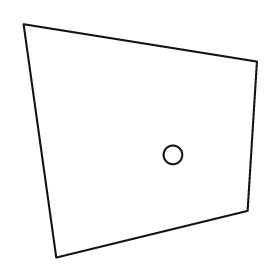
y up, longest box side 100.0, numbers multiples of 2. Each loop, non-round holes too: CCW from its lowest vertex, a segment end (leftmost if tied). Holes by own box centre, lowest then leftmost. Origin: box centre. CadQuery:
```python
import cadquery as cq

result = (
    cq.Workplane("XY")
    .moveTo(-36.0, -50.0)
    .lineTo(46.0, -30.0)
    .lineTo(50.0, 34.0)
    .lineTo(-50.0, 50.0)
    .close()
    .moveTo(14.0, -6.0)
    .circle(4.0)
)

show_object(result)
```